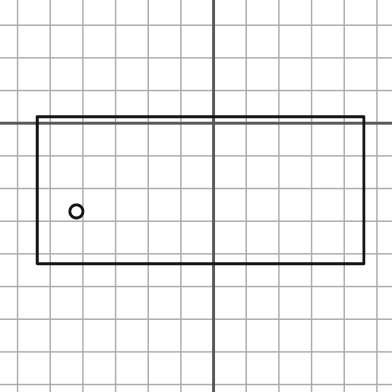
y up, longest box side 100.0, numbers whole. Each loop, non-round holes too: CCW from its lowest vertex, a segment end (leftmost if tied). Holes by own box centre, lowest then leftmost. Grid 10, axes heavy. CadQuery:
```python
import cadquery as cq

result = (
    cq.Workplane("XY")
    .moveTo(-54.0, -43.0)
    .lineTo(46.0, -43.0)
    .lineTo(46.0, 2.0)
    .lineTo(-54.0, 2.0)
    .close()
    .moveTo(-42.0, -27.0)
    .circle(2.0)
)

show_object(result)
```